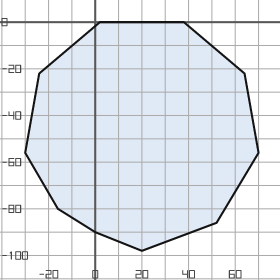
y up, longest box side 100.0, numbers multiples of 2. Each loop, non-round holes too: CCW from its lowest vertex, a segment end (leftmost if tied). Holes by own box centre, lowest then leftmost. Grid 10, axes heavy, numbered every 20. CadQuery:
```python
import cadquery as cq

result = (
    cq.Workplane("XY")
    .moveTo(20.0, -98.0)
    .lineTo(52.0, -86.0)
    .lineTo(70.0, -56.0)
    .lineTo(64.0, -22.0)
    .lineTo(38.0, 0.0)
    .lineTo(2.0, 0.0)
    .lineTo(-24.0, -22.0)
    .lineTo(-30.0, -56.0)
    .lineTo(-16.0, -80.0)
    .lineTo(0.0, -90.0)
    .close()
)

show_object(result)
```